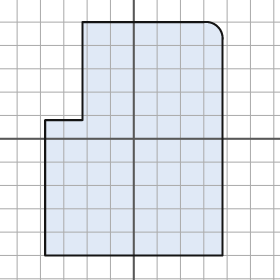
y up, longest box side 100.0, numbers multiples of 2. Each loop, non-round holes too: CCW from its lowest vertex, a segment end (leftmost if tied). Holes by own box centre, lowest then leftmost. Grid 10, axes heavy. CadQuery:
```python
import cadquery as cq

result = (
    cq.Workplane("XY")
    .moveTo(-38.0, -50.0)
    .lineTo(38.0, -50.0)
    .lineTo(38.0, 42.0)
    .threePointArc((36.0, 48.0), (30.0, 50.0))
    .lineTo(-22.0, 50.0)
    .lineTo(-22.0, 8.0)
    .lineTo(-38.0, 8.0)
    .close()
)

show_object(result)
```